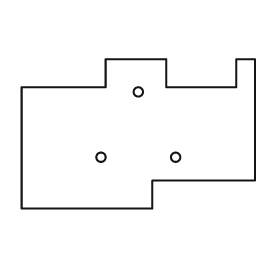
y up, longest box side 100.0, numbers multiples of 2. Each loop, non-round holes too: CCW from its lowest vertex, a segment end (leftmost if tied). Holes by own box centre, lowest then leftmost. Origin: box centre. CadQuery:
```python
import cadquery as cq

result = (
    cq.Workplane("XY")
    .moveTo(-50.0, -32.0)
    .lineTo(6.0, -32.0)
    .lineTo(6.0, -20.0)
    .lineTo(50.0, -20.0)
    .lineTo(50.0, 32.0)
    .lineTo(42.0, 32.0)
    .lineTo(42.0, 20.0)
    .lineTo(12.0, 20.0)
    .lineTo(12.0, 32.0)
    .lineTo(-14.0, 32.0)
    .lineTo(-14.0, 20.0)
    .lineTo(-50.0, 20.0)
    .close()
    .moveTo(-16.0, -10.0)
    .circle(2.0)
    .moveTo(16.0, -10.0)
    .circle(2.0)
    .moveTo(0.0, 18.0)
    .circle(2.0)
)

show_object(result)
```